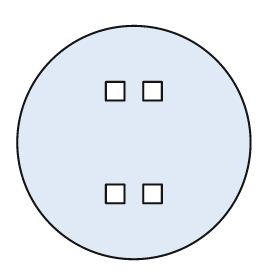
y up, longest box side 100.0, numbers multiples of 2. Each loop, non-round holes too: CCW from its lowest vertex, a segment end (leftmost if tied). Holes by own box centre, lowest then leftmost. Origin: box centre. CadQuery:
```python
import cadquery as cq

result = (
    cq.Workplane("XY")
    .moveTo(0.0, 0.0)
    .circle(50.0)
    .moveTo(-12.0, -26.0)
    .lineTo(-4.0, -26.0)
    .lineTo(-4.0, -18.0)
    .lineTo(-12.0, -18.0)
    .close()
    .moveTo(4.0, -26.0)
    .lineTo(12.0, -26.0)
    .lineTo(12.0, -18.0)
    .lineTo(4.0, -18.0)
    .close()
    .moveTo(-12.0, 18.0)
    .lineTo(-4.0, 18.0)
    .lineTo(-4.0, 26.0)
    .lineTo(-12.0, 26.0)
    .close()
    .moveTo(4.0, 18.0)
    .lineTo(12.0, 18.0)
    .lineTo(12.0, 26.0)
    .lineTo(4.0, 26.0)
    .close()
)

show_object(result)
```